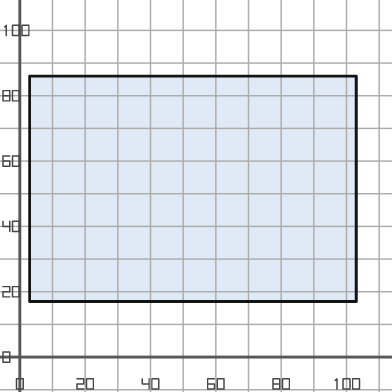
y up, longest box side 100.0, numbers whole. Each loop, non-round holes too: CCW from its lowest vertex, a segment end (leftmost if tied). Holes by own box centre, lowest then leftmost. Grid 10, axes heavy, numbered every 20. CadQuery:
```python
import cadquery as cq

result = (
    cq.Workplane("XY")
    .moveTo(3.0, 17.0)
    .lineTo(103.0, 17.0)
    .lineTo(103.0, 86.0)
    .lineTo(3.0, 86.0)
    .close()
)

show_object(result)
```